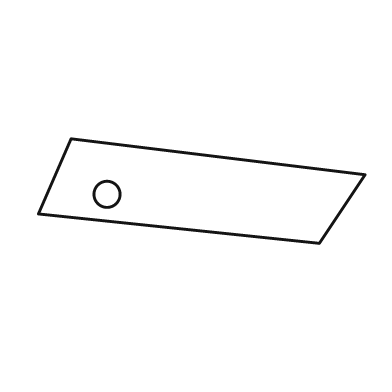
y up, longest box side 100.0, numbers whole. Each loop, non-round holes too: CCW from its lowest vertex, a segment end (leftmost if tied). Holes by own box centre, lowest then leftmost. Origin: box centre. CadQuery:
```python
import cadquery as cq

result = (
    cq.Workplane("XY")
    .moveTo(36.0, -16.0)
    .lineTo(50.0, 5.0)
    .lineTo(-40.0, 16.0)
    .lineTo(-50.0, -7.0)
    .close()
    .moveTo(-29.0, -1.0)
    .circle(4.0)
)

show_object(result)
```